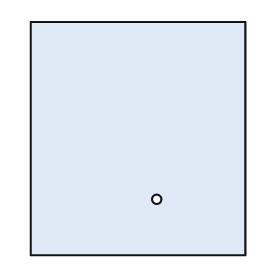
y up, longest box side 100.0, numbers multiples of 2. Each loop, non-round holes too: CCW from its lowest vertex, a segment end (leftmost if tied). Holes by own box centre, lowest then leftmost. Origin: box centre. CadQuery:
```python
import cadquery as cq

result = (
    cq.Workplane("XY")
    .moveTo(-46.0, -50.0)
    .lineTo(46.0, -50.0)
    .lineTo(46.0, 50.0)
    .lineTo(-46.0, 50.0)
    .close()
    .moveTo(8.0, -26.0)
    .circle(2.0)
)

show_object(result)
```